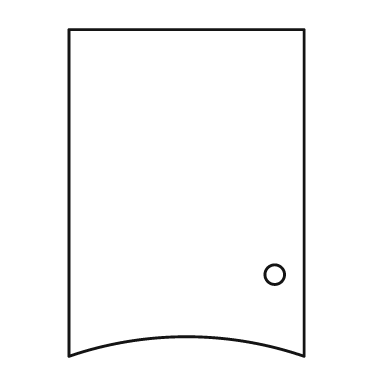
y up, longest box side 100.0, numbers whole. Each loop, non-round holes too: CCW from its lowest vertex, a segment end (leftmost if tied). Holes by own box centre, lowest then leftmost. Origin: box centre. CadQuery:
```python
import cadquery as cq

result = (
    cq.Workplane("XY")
    .moveTo(-36.0, -50.0)
    .threePointArc((0.0, -44.0), (36.0, -50.0))
    .lineTo(36.0, 50.0)
    .lineTo(-36.0, 50.0)
    .close()
    .moveTo(27.0, -25.0)
    .circle(3.0)
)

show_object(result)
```